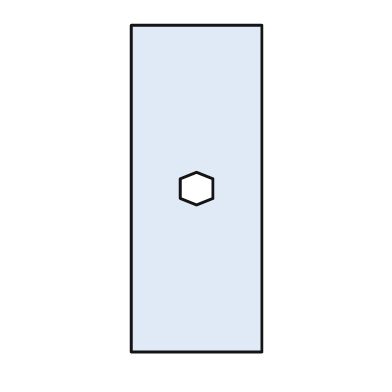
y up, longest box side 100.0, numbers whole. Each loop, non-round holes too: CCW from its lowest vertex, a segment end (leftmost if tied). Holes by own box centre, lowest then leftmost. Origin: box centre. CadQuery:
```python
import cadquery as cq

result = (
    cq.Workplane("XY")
    .moveTo(-20.0, -50.0)
    .lineTo(20.0, -50.0)
    .lineTo(20.0, 50.0)
    .lineTo(-20.0, 50.0)
    .close()
    .moveTo(0.0, -5.0)
    .lineTo(5.0, -3.0)
    .lineTo(5.0, 3.0)
    .lineTo(0.0, 5.0)
    .lineTo(-5.0, 3.0)
    .lineTo(-5.0, -3.0)
    .close()
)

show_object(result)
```